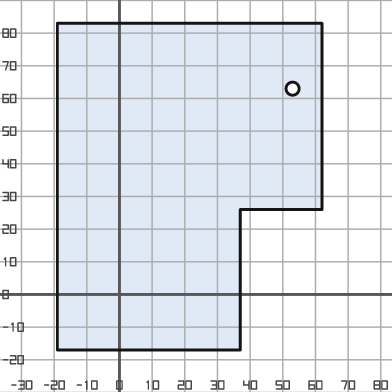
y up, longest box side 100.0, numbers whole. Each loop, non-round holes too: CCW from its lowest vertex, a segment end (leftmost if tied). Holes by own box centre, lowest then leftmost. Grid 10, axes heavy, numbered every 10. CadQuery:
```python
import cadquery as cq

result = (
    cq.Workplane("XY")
    .moveTo(-19.0, -17.0)
    .lineTo(37.0, -17.0)
    .lineTo(37.0, 26.0)
    .lineTo(62.0, 26.0)
    .lineTo(62.0, 83.0)
    .lineTo(-19.0, 83.0)
    .close()
    .moveTo(53.0, 63.0)
    .circle(2.0)
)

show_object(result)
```